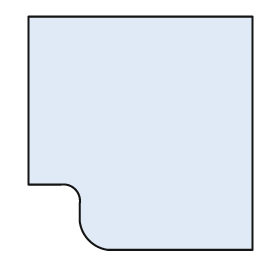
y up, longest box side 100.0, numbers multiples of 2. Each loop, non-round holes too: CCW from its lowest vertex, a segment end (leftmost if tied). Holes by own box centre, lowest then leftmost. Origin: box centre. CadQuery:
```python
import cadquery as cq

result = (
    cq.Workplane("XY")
    .moveTo(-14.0, -50.0)
    .lineTo(48.0, -50.0)
    .lineTo(48.0, 50.0)
    .lineTo(-48.0, 50.0)
    .lineTo(-48.0, -22.0)
    .lineTo(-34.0, -22.0)
    .threePointArc((-28.0, -24.0), (-26.0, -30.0))
    .lineTo(-26.0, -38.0)
    .threePointArc((-22.0, -46.0), (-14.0, -50.0))
    .close()
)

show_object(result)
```